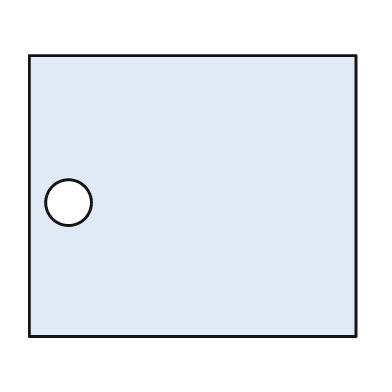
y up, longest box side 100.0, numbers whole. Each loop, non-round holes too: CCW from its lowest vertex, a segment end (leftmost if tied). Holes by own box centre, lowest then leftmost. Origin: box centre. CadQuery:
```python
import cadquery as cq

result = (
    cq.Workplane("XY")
    .moveTo(-50.0, -43.0)
    .lineTo(50.0, -43.0)
    .lineTo(50.0, 43.0)
    .lineTo(-50.0, 43.0)
    .close()
    .moveTo(-38.0, -2.0)
    .circle(7.0)
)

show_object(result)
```